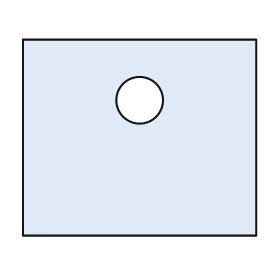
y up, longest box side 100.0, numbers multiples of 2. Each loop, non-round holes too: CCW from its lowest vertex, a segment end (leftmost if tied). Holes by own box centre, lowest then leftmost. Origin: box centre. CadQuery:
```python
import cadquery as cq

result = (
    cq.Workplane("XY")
    .moveTo(-50.0, -42.0)
    .lineTo(50.0, -42.0)
    .lineTo(50.0, 42.0)
    .lineTo(-50.0, 42.0)
    .close()
    .moveTo(0.0, 16.0)
    .circle(10.0)
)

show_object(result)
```